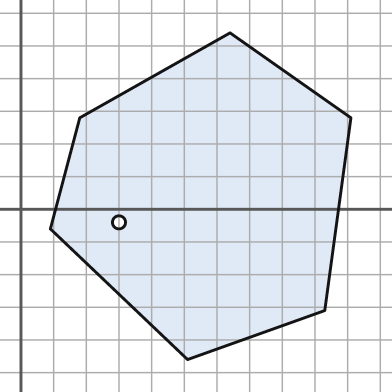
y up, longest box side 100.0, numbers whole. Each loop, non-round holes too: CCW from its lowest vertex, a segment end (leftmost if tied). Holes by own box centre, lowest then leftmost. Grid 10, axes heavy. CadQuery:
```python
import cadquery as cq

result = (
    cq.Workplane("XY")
    .moveTo(51.0, -46.0)
    .lineTo(93.0, -31.0)
    .lineTo(101.0, 28.0)
    .lineTo(64.0, 54.0)
    .lineTo(18.0, 28.0)
    .lineTo(9.0, -6.0)
    .close()
    .moveTo(30.0, -4.0)
    .circle(2.0)
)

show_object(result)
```